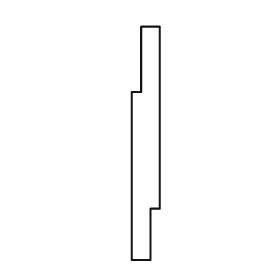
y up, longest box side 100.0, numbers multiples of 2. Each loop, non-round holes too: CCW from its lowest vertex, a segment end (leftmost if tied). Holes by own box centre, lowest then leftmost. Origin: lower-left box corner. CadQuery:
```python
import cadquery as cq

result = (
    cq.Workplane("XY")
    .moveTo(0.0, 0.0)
    .lineTo(8.0, 0.0)
    .lineTo(8.0, 22.0)
    .lineTo(12.0, 22.0)
    .lineTo(12.0, 100.0)
    .lineTo(4.0, 100.0)
    .lineTo(4.0, 72.0)
    .lineTo(0.0, 72.0)
    .close()
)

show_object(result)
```